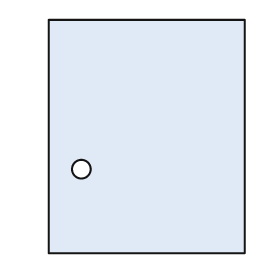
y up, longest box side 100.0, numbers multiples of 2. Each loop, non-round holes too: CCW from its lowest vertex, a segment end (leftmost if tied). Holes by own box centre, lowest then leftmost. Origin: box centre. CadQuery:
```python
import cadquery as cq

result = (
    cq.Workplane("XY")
    .moveTo(-42.0, -50.0)
    .lineTo(42.0, -50.0)
    .lineTo(42.0, 50.0)
    .lineTo(-42.0, 50.0)
    .close()
    .moveTo(-28.0, -14.0)
    .circle(4.0)
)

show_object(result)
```